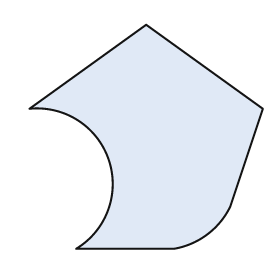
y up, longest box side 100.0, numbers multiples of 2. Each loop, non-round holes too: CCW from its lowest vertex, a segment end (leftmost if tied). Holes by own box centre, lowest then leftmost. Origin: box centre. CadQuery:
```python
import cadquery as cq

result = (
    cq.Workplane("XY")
    .moveTo(-30.0, -48.0)
    .lineTo(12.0, -48.0)
    .threePointArc((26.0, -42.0), (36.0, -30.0))
    .lineTo(50.0, 12.0)
    .lineTo(0.0, 48.0)
    .lineTo(-50.0, 12.0)
    .threePointArc((-16.0, -10.0), (-30.0, -48.0))
    .close()
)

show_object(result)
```